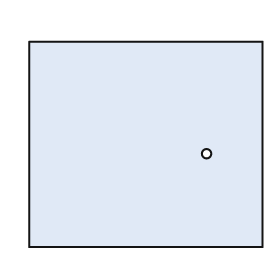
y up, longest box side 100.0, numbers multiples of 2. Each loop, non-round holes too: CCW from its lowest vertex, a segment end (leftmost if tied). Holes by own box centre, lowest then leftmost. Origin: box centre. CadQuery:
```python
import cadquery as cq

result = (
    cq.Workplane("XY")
    .moveTo(-50.0, -44.0)
    .lineTo(50.0, -44.0)
    .lineTo(50.0, 44.0)
    .lineTo(-50.0, 44.0)
    .close()
    .moveTo(26.0, -4.0)
    .circle(2.0)
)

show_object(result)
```